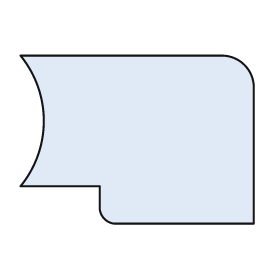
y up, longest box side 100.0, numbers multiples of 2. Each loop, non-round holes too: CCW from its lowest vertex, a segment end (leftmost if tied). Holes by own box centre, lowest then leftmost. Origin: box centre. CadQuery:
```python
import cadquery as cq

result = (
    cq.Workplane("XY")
    .moveTo(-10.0, -36.0)
    .lineTo(50.0, -36.0)
    .lineTo(50.0, 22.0)
    .threePointArc((46.0, 32.0), (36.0, 36.0))
    .lineTo(-50.0, 36.0)
    .threePointArc((-40.0, 8.0), (-50.0, -20.0))
    .lineTo(-16.0, -20.0)
    .lineTo(-16.0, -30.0)
    .threePointArc((-14.0, -34.0), (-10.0, -36.0))
    .close()
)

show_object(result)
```